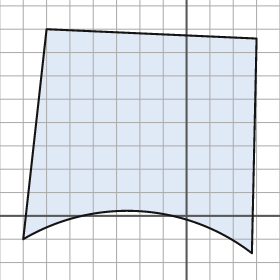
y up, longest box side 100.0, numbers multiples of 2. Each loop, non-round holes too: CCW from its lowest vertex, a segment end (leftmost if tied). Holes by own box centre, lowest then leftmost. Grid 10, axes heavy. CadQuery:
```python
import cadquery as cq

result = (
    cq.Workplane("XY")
    .moveTo(28.0, -16.0)
    .lineTo(30.0, 76.0)
    .lineTo(-60.0, 80.0)
    .lineTo(-70.0, -10.0)
    .threePointArc((-20.0, 2.0), (28.0, -16.0))
    .close()
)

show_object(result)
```